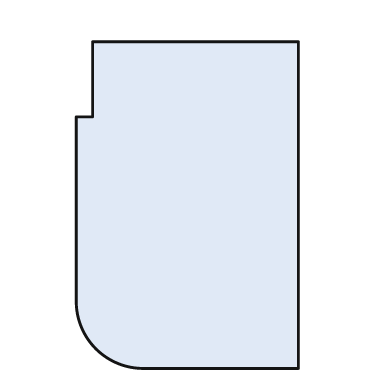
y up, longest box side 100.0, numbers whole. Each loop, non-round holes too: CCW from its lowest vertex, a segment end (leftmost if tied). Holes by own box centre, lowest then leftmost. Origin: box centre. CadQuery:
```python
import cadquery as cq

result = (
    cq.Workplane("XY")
    .moveTo(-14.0, -50.0)
    .lineTo(34.0, -50.0)
    .lineTo(34.0, 50.0)
    .lineTo(-29.0, 50.0)
    .lineTo(-29.0, 27.0)
    .lineTo(-34.0, 27.0)
    .lineTo(-34.0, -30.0)
    .threePointArc((-28.0, -44.0), (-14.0, -50.0))
    .close()
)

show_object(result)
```